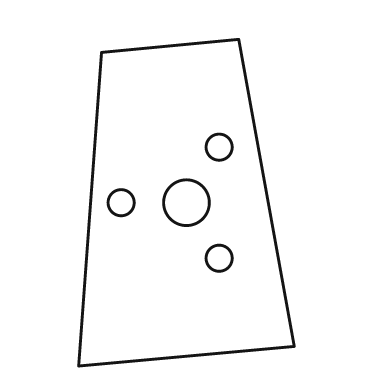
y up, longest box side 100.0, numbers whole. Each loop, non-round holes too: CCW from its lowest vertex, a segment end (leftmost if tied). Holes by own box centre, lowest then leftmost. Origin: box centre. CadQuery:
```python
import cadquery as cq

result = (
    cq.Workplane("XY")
    .moveTo(-33.0, -50.0)
    .lineTo(33.0, -44.0)
    .lineTo(16.0, 50.0)
    .lineTo(-26.0, 46.0)
    .close()
    .moveTo(10.0, -17.0)
    .circle(4.0)
    .moveTo(-20.0, 0.0)
    .circle(4.0)
    .moveTo(0.0, 0.0)
    .circle(7.0)
    .moveTo(10.0, 17.0)
    .circle(4.0)
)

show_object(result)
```